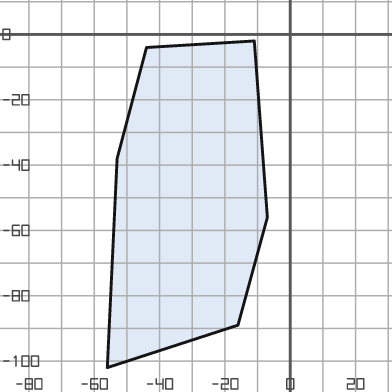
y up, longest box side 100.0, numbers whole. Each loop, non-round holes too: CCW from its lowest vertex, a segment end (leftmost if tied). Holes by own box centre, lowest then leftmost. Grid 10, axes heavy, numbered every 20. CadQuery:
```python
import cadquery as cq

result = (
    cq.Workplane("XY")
    .moveTo(-56.0, -102.0)
    .lineTo(-16.0, -89.0)
    .lineTo(-7.0, -56.0)
    .lineTo(-11.0, -2.0)
    .lineTo(-44.0, -4.0)
    .lineTo(-53.0, -38.0)
    .close()
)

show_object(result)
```